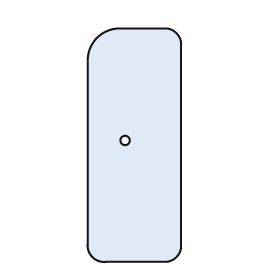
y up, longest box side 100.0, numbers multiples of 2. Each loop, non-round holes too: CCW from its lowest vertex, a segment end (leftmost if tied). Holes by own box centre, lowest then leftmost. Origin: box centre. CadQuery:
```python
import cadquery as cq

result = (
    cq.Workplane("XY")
    .moveTo(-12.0, -50.0)
    .lineTo(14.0, -50.0)
    .threePointArc((18.0, -48.0), (20.0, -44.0))
    .lineTo(20.0, 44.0)
    .threePointArc((18.0, 48.0), (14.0, 50.0))
    .lineTo(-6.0, 50.0)
    .threePointArc((-16.0, 46.0), (-20.0, 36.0))
    .lineTo(-20.0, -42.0)
    .threePointArc((-18.0, -48.0), (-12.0, -50.0))
    .close()
    .moveTo(-4.0, 2.0)
    .circle(2.0)
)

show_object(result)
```